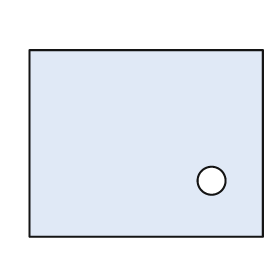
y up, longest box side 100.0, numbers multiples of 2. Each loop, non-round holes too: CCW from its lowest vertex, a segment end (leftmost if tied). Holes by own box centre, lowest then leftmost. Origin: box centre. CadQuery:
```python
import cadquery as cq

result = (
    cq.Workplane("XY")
    .moveTo(-50.0, -40.0)
    .lineTo(50.0, -40.0)
    .lineTo(50.0, 40.0)
    .lineTo(-50.0, 40.0)
    .close()
    .moveTo(28.0, -16.0)
    .circle(6.0)
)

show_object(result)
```